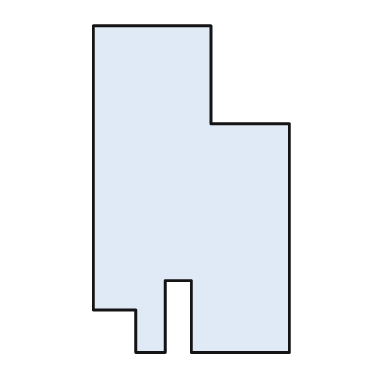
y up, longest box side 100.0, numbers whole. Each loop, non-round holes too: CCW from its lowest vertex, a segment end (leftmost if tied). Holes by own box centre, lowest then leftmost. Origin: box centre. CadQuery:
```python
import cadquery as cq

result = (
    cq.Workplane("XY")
    .moveTo(-17.0, -50.0)
    .lineTo(-8.0, -50.0)
    .lineTo(-8.0, -28.0)
    .lineTo(0.0, -28.0)
    .lineTo(0.0, -50.0)
    .lineTo(30.0, -50.0)
    .lineTo(30.0, 20.0)
    .lineTo(6.0, 20.0)
    .lineTo(6.0, 50.0)
    .lineTo(-30.0, 50.0)
    .lineTo(-30.0, -37.0)
    .lineTo(-17.0, -37.0)
    .close()
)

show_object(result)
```